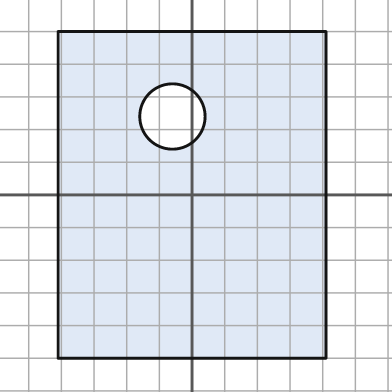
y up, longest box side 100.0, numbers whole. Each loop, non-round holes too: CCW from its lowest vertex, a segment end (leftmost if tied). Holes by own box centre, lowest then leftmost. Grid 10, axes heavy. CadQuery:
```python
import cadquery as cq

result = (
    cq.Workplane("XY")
    .moveTo(-41.0, -50.0)
    .lineTo(41.0, -50.0)
    .lineTo(41.0, 50.0)
    .lineTo(-41.0, 50.0)
    .close()
    .moveTo(-6.0, 24.0)
    .circle(10.0)
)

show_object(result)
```